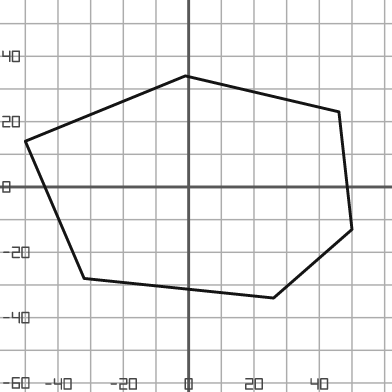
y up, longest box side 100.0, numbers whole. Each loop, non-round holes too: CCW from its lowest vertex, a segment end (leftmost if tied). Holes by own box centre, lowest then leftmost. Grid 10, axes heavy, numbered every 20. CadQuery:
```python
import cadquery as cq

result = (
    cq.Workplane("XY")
    .moveTo(26.0, -34.0)
    .lineTo(50.0, -13.0)
    .lineTo(46.0, 23.0)
    .lineTo(-1.0, 34.0)
    .lineTo(-50.0, 14.0)
    .lineTo(-32.0, -28.0)
    .close()
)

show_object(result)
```